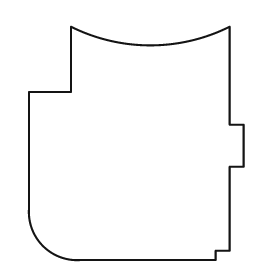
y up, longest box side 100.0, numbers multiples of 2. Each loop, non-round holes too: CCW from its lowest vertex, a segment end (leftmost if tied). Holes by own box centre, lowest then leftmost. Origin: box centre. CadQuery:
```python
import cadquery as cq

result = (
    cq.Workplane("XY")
    .moveTo(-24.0, -50.0)
    .lineTo(34.0, -50.0)
    .lineTo(34.0, -46.0)
    .lineTo(40.0, -46.0)
    .lineTo(40.0, -10.0)
    .lineTo(46.0, -10.0)
    .lineTo(46.0, 8.0)
    .lineTo(40.0, 8.0)
    .lineTo(40.0, 50.0)
    .threePointArc((6.0, 42.0), (-28.0, 50.0))
    .lineTo(-28.0, 22.0)
    .lineTo(-46.0, 22.0)
    .lineTo(-46.0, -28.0)
    .threePointArc((-40.0, -44.0), (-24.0, -50.0))
    .close()
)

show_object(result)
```